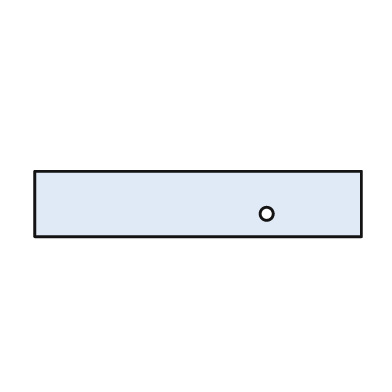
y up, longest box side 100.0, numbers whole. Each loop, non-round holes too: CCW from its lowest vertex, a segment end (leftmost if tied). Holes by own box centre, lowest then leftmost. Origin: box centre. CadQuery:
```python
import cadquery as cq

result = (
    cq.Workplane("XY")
    .moveTo(-50.0, -10.0)
    .lineTo(50.0, -10.0)
    .lineTo(50.0, 10.0)
    .lineTo(-50.0, 10.0)
    .close()
    .moveTo(21.0, -3.0)
    .circle(2.0)
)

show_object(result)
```